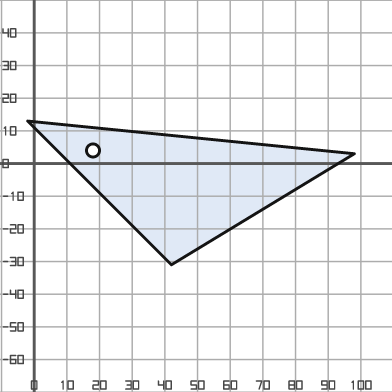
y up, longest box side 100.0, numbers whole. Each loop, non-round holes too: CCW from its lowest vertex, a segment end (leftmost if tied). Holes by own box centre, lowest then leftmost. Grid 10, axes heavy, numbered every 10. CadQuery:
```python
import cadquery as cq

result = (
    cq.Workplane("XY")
    .moveTo(42.0, -31.0)
    .lineTo(98.0, 3.0)
    .lineTo(-2.0, 13.0)
    .close()
    .moveTo(18.0, 4.0)
    .circle(2.0)
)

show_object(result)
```